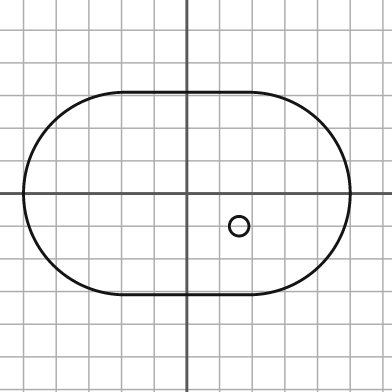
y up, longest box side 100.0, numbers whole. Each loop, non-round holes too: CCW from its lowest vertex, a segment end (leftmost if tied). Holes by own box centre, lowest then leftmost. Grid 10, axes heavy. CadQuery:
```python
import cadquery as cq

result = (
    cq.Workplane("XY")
    .moveTo(-19.0, -31.0)
    .lineTo(19.0, -31.0)
    .threePointArc((50.0, 0.0), (19.0, 31.0))
    .lineTo(-19.0, 31.0)
    .threePointArc((-50.0, 0.0), (-19.0, -31.0))
    .close()
    .moveTo(16.0, -10.0)
    .circle(3.0)
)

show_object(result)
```